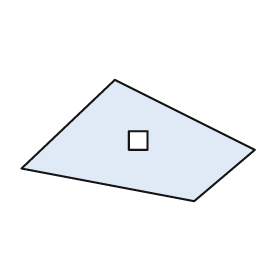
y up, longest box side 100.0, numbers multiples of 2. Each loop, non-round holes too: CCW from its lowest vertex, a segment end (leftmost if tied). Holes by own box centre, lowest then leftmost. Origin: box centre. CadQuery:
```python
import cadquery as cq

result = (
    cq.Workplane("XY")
    .moveTo(24.0, -26.0)
    .lineTo(50.0, -4.0)
    .lineTo(-10.0, 26.0)
    .lineTo(-50.0, -12.0)
    .close()
    .moveTo(-4.0, -4.0)
    .lineTo(4.0, -4.0)
    .lineTo(4.0, 4.0)
    .lineTo(-4.0, 4.0)
    .close()
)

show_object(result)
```